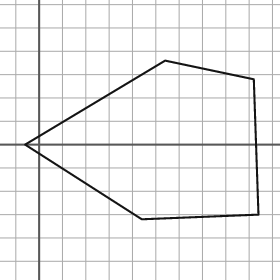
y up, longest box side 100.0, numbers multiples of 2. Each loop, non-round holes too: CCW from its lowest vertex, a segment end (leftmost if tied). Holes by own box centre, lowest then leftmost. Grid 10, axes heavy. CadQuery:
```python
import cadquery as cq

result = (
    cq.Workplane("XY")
    .moveTo(44.0, -32.0)
    .lineTo(94.0, -30.0)
    .lineTo(92.0, 28.0)
    .lineTo(54.0, 36.0)
    .lineTo(-6.0, 0.0)
    .close()
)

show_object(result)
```